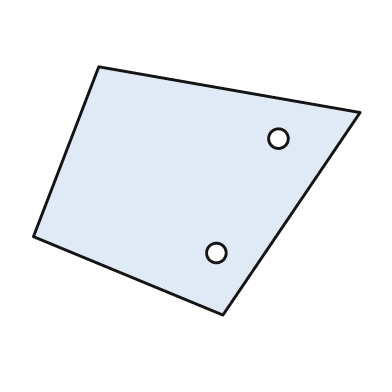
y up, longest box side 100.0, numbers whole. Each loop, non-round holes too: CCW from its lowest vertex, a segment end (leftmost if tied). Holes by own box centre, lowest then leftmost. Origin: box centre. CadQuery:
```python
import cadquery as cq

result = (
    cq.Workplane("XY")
    .moveTo(8.0, -38.0)
    .lineTo(50.0, 24.0)
    .lineTo(-30.0, 38.0)
    .lineTo(-50.0, -14.0)
    .close()
    .moveTo(6.0, -19.0)
    .circle(3.0)
    .moveTo(25.0, 16.0)
    .circle(3.0)
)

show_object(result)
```